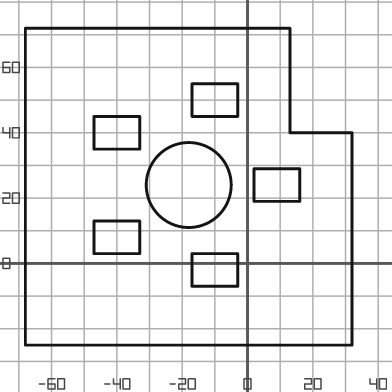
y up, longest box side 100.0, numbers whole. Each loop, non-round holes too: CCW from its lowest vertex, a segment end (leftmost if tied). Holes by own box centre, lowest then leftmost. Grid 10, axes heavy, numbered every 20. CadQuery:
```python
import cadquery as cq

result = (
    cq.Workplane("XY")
    .moveTo(-68.0, -25.0)
    .lineTo(32.0, -25.0)
    .lineTo(32.0, 40.0)
    .lineTo(13.0, 40.0)
    .lineTo(13.0, 72.0)
    .lineTo(-68.0, 72.0)
    .close()
    .moveTo(-17.0, -7.0)
    .lineTo(-3.0, -7.0)
    .lineTo(-3.0, 3.0)
    .lineTo(-17.0, 3.0)
    .close()
    .moveTo(-47.0, 3.0)
    .lineTo(-33.0, 3.0)
    .lineTo(-33.0, 13.0)
    .lineTo(-47.0, 13.0)
    .close()
    .moveTo(-18.0, 24.0)
    .circle(13.0)
    .moveTo(2.0, 19.0)
    .lineTo(16.0, 19.0)
    .lineTo(16.0, 29.0)
    .lineTo(2.0, 29.0)
    .close()
    .moveTo(-47.0, 35.0)
    .lineTo(-33.0, 35.0)
    .lineTo(-33.0, 45.0)
    .lineTo(-47.0, 45.0)
    .close()
    .moveTo(-17.0, 45.0)
    .lineTo(-3.0, 45.0)
    .lineTo(-3.0, 55.0)
    .lineTo(-17.0, 55.0)
    .close()
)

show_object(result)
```